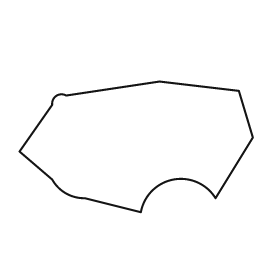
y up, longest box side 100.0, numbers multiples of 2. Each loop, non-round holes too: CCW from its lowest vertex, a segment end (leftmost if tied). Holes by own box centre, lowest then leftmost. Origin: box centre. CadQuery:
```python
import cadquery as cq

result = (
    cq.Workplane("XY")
    .moveTo(2.0, -28.0)
    .threePointArc((16.0, -14.0), (34.0, -22.0))
    .lineTo(50.0, 4.0)
    .lineTo(44.0, 24.0)
    .lineTo(10.0, 28.0)
    .lineTo(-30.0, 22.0)
    .threePointArc((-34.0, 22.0), (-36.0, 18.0))
    .lineTo(-50.0, -2.0)
    .lineTo(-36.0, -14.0)
    .threePointArc((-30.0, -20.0), (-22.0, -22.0))
    .close()
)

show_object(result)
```